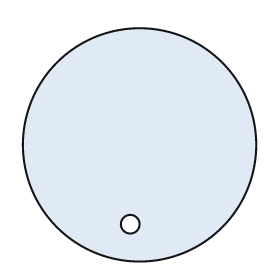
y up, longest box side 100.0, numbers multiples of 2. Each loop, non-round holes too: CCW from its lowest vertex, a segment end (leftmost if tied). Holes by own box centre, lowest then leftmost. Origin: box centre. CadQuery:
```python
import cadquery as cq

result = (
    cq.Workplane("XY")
    .moveTo(0.0, 0.0)
    .circle(50.0)
    .moveTo(-4.0, -34.0)
    .circle(4.0)
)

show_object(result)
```